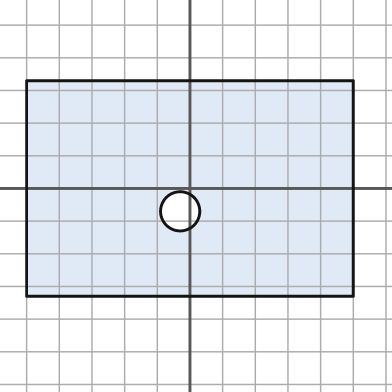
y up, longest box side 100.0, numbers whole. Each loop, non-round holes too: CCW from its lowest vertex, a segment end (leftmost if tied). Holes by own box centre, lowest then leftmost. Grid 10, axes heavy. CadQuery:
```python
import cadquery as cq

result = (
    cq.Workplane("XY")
    .moveTo(-50.0, -33.0)
    .lineTo(50.0, -33.0)
    .lineTo(50.0, 33.0)
    .lineTo(-50.0, 33.0)
    .close()
    .moveTo(-3.0, -7.0)
    .circle(6.0)
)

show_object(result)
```